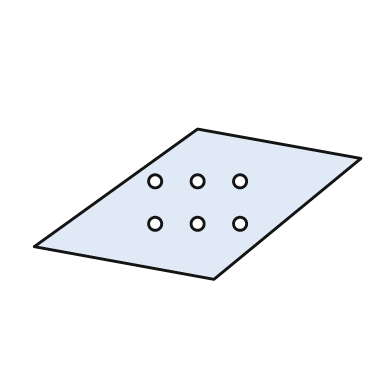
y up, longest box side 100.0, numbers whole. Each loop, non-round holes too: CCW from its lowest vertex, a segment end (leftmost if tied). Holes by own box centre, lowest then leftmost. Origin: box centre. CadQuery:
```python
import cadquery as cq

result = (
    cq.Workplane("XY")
    .moveTo(5.0, -23.0)
    .lineTo(50.0, 14.0)
    .lineTo(0.0, 23.0)
    .lineTo(-50.0, -13.0)
    .close()
    .moveTo(-13.0, -6.0)
    .circle(2.0)
    .moveTo(0.0, -6.0)
    .circle(2.0)
    .moveTo(13.0, -6.0)
    .circle(2.0)
    .moveTo(-13.0, 7.0)
    .circle(2.0)
    .moveTo(0.0, 7.0)
    .circle(2.0)
    .moveTo(13.0, 7.0)
    .circle(2.0)
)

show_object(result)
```